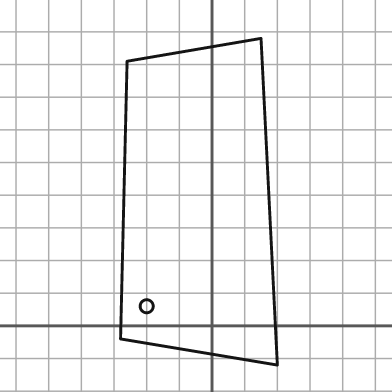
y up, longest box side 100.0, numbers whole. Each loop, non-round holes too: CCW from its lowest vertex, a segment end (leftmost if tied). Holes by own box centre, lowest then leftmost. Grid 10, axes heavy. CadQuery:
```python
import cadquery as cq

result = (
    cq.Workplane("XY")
    .moveTo(20.0, -12.0)
    .lineTo(15.0, 88.0)
    .lineTo(-26.0, 81.0)
    .lineTo(-28.0, -4.0)
    .close()
    .moveTo(-20.0, 6.0)
    .circle(2.0)
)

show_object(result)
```